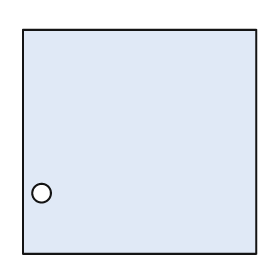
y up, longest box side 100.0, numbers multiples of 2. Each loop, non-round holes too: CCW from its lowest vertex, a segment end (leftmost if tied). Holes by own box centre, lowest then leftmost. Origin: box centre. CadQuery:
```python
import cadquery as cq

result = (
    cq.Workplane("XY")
    .moveTo(-50.0, -48.0)
    .lineTo(50.0, -48.0)
    .lineTo(50.0, 48.0)
    .lineTo(-50.0, 48.0)
    .close()
    .moveTo(-42.0, -22.0)
    .circle(4.0)
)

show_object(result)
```